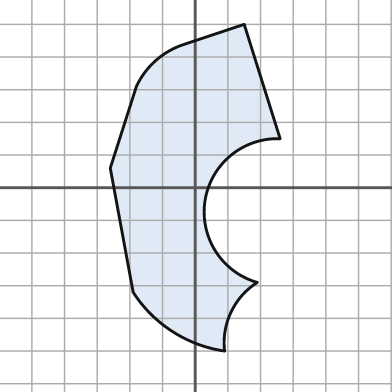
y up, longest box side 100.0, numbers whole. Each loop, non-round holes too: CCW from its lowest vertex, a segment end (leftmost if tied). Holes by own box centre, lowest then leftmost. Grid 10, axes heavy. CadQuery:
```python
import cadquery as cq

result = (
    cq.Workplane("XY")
    .moveTo(9.0, -50.0)
    .threePointArc((11.0, -38.0), (19.0, -29.0))
    .threePointArc((3.0, -4.0), (26.0, 15.0))
    .lineTo(15.0, 50.0)
    .lineTo(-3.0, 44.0)
    .threePointArc((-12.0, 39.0), (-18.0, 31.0))
    .lineTo(-26.0, 6.0)
    .lineTo(-19.0, -32.0)
    .threePointArc((-7.0, -44.0), (9.0, -50.0))
    .close()
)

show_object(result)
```